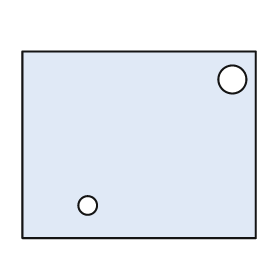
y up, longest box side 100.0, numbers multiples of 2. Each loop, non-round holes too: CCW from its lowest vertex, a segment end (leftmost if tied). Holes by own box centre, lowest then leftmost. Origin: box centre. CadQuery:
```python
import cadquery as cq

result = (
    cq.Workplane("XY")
    .moveTo(-50.0, -40.0)
    .lineTo(50.0, -40.0)
    .lineTo(50.0, 40.0)
    .lineTo(-50.0, 40.0)
    .close()
    .moveTo(-22.0, -26.0)
    .circle(4.0)
    .moveTo(40.0, 28.0)
    .circle(6.0)
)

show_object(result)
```